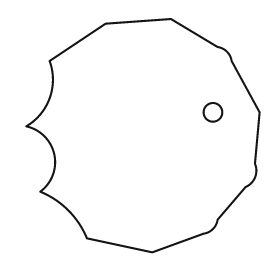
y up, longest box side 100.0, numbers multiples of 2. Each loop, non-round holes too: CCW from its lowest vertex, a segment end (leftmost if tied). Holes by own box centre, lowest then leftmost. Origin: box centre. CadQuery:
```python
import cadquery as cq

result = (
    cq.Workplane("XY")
    .moveTo(4.0, -50.0)
    .lineTo(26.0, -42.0)
    .threePointArc((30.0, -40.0), (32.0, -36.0))
    .lineTo(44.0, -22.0)
    .threePointArc((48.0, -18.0), (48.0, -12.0))
    .lineTo(50.0, 10.0)
    .lineTo(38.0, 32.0)
    .threePointArc((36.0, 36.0), (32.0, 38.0))
    .lineTo(12.0, 50.0)
    .lineTo(-16.0, 48.0)
    .lineTo(-40.0, 32.0)
    .threePointArc((-40.0, 16.0), (-50.0, 4.0))
    .threePointArc((-38.0, -8.0), (-44.0, -24.0))
    .threePointArc((-32.0, -32.0), (-24.0, -44.0))
    .close()
    .moveTo(30.0, 10.0)
    .circle(4.0)
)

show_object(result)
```